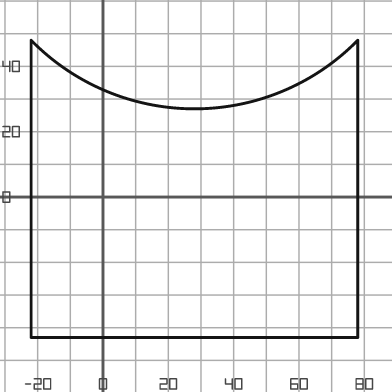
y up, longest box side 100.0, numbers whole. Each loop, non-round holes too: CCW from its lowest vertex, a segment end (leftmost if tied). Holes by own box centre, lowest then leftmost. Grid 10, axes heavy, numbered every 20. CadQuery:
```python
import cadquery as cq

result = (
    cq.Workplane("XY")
    .moveTo(-22.0, -43.0)
    .lineTo(78.0, -43.0)
    .lineTo(78.0, 48.0)
    .threePointArc((28.0, 27.0), (-22.0, 48.0))
    .close()
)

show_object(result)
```